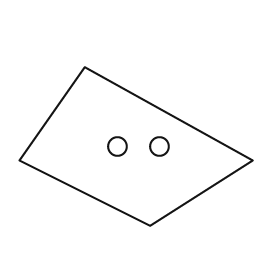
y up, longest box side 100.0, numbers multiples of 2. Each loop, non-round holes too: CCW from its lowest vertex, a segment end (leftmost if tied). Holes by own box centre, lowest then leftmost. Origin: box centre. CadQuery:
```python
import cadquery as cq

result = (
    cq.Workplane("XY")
    .moveTo(6.0, -34.0)
    .lineTo(50.0, -6.0)
    .lineTo(-22.0, 34.0)
    .lineTo(-50.0, -6.0)
    .close()
    .moveTo(-8.0, 0.0)
    .circle(4.0)
    .moveTo(10.0, 0.0)
    .circle(4.0)
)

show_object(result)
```